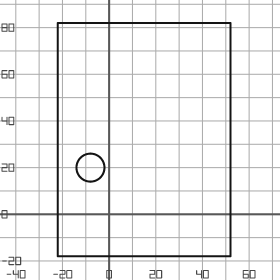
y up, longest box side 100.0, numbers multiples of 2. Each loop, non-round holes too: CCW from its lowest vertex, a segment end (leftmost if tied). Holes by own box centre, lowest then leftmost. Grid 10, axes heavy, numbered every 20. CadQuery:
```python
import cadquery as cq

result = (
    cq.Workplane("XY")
    .moveTo(-22.0, -18.0)
    .lineTo(52.0, -18.0)
    .lineTo(52.0, 82.0)
    .lineTo(-22.0, 82.0)
    .close()
    .moveTo(-8.0, 20.0)
    .circle(6.0)
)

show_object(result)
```